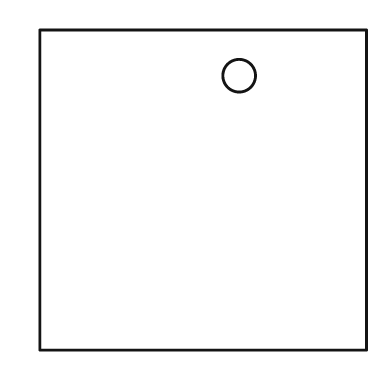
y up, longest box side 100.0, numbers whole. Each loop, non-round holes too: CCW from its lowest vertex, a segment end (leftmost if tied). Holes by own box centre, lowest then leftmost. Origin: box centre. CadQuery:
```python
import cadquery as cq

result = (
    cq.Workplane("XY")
    .moveTo(-50.0, -49.0)
    .lineTo(50.0, -49.0)
    .lineTo(50.0, 49.0)
    .lineTo(-50.0, 49.0)
    .close()
    .moveTo(11.0, 35.0)
    .circle(5.0)
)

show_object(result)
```